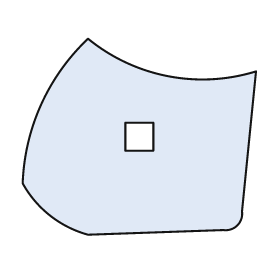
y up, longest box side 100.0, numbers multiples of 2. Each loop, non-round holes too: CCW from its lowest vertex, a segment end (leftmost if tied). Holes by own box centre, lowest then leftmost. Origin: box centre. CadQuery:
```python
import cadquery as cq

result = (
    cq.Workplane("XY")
    .moveTo(-22.0, -42.0)
    .lineTo(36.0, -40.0)
    .threePointArc((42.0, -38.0), (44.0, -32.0))
    .lineTo(50.0, 28.0)
    .threePointArc((12.0, 26.0), (-22.0, 42.0))
    .threePointArc((-42.0, 14.0), (-50.0, -20.0))
    .threePointArc((-38.0, -34.0), (-22.0, -42.0))
    .close()
    .moveTo(-6.0, -6.0)
    .lineTo(6.0, -6.0)
    .lineTo(6.0, 6.0)
    .lineTo(-6.0, 6.0)
    .close()
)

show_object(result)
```